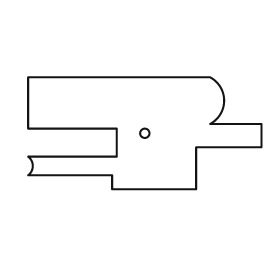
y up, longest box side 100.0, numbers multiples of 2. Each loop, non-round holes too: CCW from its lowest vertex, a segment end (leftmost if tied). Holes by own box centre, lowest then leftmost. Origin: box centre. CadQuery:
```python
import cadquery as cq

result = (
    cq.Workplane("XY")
    .moveTo(-14.0, -24.0)
    .lineTo(22.0, -24.0)
    .lineTo(22.0, -6.0)
    .lineTo(50.0, -6.0)
    .lineTo(50.0, 4.0)
    .lineTo(28.0, 4.0)
    .threePointArc((34.0, 14.0), (28.0, 24.0))
    .lineTo(-50.0, 24.0)
    .lineTo(-50.0, 2.0)
    .lineTo(-12.0, 2.0)
    .lineTo(-12.0, -10.0)
    .lineTo(-50.0, -10.0)
    .threePointArc((-48.0, -14.0), (-50.0, -18.0))
    .lineTo(-14.0, -18.0)
    .close()
    .moveTo(0.0, 0.0)
    .circle(2.0)
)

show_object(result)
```